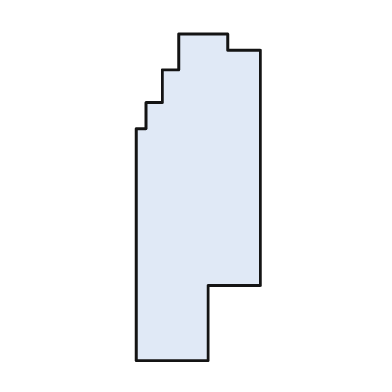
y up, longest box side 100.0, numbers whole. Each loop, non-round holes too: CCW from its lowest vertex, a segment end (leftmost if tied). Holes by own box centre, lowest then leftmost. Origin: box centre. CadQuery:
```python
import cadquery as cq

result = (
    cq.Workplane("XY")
    .moveTo(-19.0, -50.0)
    .lineTo(3.0, -50.0)
    .lineTo(3.0, -27.0)
    .lineTo(19.0, -27.0)
    .lineTo(19.0, 45.0)
    .lineTo(9.0, 45.0)
    .lineTo(9.0, 50.0)
    .lineTo(-6.0, 50.0)
    .lineTo(-6.0, 39.0)
    .lineTo(-11.0, 39.0)
    .lineTo(-11.0, 29.0)
    .lineTo(-16.0, 29.0)
    .lineTo(-16.0, 21.0)
    .lineTo(-19.0, 21.0)
    .close()
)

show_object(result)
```